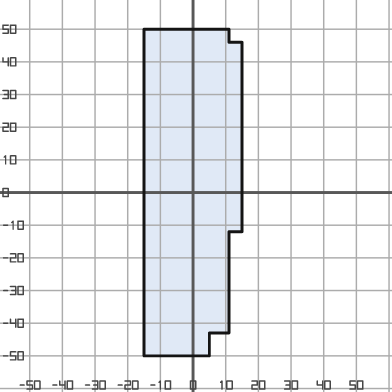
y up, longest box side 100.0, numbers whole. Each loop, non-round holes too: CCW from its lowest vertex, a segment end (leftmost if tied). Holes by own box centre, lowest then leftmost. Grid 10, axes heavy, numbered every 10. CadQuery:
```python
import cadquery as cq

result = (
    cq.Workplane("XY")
    .moveTo(-15.0, -50.0)
    .lineTo(5.0, -50.0)
    .lineTo(5.0, -43.0)
    .lineTo(11.0, -43.0)
    .lineTo(11.0, -12.0)
    .lineTo(15.0, -12.0)
    .lineTo(15.0, 46.0)
    .lineTo(11.0, 46.0)
    .lineTo(11.0, 50.0)
    .lineTo(-15.0, 50.0)
    .close()
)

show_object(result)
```